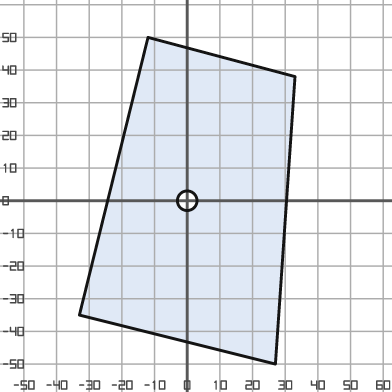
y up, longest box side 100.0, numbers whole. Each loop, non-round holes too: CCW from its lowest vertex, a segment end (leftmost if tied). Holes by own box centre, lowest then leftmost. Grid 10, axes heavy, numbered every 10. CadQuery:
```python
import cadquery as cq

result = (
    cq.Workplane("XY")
    .moveTo(27.0, -50.0)
    .lineTo(33.0, 38.0)
    .lineTo(-12.0, 50.0)
    .lineTo(-33.0, -35.0)
    .close()
    .moveTo(0.0, 0.0)
    .circle(3.0)
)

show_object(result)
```